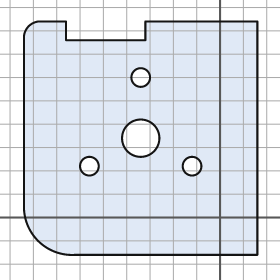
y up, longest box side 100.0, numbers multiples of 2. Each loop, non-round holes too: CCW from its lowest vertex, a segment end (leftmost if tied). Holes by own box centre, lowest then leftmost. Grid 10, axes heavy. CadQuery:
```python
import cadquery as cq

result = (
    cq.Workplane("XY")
    .moveTo(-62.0, -16.0)
    .lineTo(16.0, -16.0)
    .lineTo(16.0, 84.0)
    .lineTo(-32.0, 84.0)
    .lineTo(-32.0, 76.0)
    .lineTo(-66.0, 76.0)
    .lineTo(-66.0, 84.0)
    .lineTo(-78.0, 84.0)
    .threePointArc((-82.0, 82.0), (-84.0, 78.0))
    .lineTo(-84.0, 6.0)
    .threePointArc((-78.0, -10.0), (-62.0, -16.0))
    .close()
    .moveTo(-56.0, 22.0)
    .circle(4.0)
    .moveTo(-12.0, 22.0)
    .circle(4.0)
    .moveTo(-34.0, 34.0)
    .circle(8.0)
    .moveTo(-34.0, 60.0)
    .circle(4.0)
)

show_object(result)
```